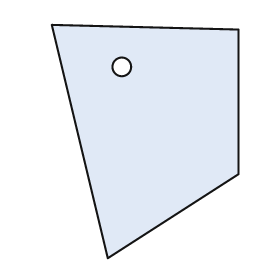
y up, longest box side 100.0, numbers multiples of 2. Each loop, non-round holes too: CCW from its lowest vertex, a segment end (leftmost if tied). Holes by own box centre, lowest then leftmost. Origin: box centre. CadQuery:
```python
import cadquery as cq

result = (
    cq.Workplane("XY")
    .moveTo(-16.0, -50.0)
    .lineTo(40.0, -14.0)
    .lineTo(40.0, 48.0)
    .lineTo(-40.0, 50.0)
    .close()
    .moveTo(-10.0, 32.0)
    .circle(4.0)
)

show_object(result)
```